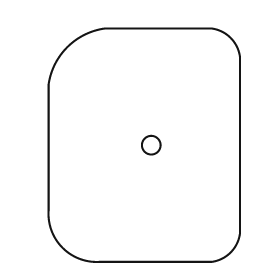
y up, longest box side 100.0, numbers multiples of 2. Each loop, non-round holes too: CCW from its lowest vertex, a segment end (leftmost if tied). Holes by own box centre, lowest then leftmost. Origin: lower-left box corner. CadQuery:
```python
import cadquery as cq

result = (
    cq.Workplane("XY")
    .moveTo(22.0, 0.0)
    .lineTo(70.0, 0.0)
    .threePointArc((78.0, 4.0), (82.0, 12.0))
    .lineTo(82.0, 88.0)
    .threePointArc((78.0, 96.0), (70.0, 100.0))
    .lineTo(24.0, 100.0)
    .threePointArc((8.0, 92.0), (0.0, 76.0))
    .lineTo(0.0, 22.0)
    .threePointArc((6.0, 6.0), (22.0, 0.0))
    .close()
    .moveTo(44.0, 50.0)
    .circle(4.0)
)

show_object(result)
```